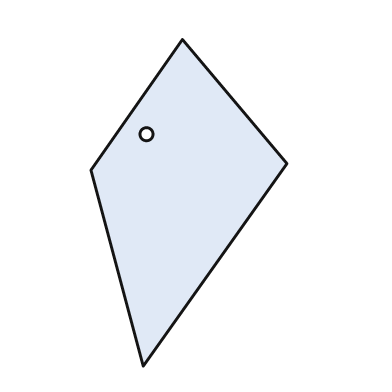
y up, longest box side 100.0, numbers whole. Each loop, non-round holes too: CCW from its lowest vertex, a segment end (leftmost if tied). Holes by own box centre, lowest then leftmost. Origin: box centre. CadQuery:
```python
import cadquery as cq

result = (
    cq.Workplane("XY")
    .moveTo(-14.0, -50.0)
    .lineTo(30.0, 12.0)
    .lineTo(-2.0, 50.0)
    .lineTo(-30.0, 10.0)
    .close()
    .moveTo(-13.0, 21.0)
    .circle(2.0)
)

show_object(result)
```